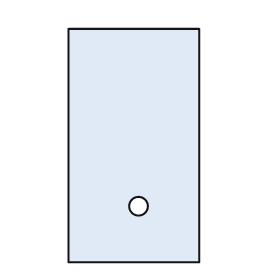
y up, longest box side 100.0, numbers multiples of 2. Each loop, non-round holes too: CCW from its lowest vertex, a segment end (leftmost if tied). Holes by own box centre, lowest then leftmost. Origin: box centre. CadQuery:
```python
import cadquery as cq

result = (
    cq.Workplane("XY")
    .moveTo(-28.0, -50.0)
    .lineTo(28.0, -50.0)
    .lineTo(28.0, 50.0)
    .lineTo(-28.0, 50.0)
    .close()
    .moveTo(2.0, -26.0)
    .circle(4.0)
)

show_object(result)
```